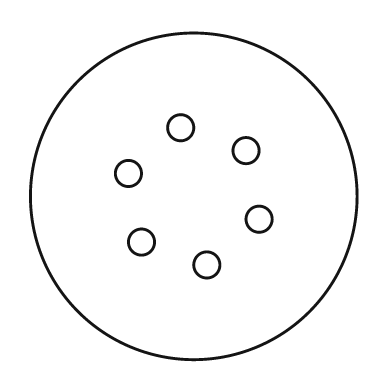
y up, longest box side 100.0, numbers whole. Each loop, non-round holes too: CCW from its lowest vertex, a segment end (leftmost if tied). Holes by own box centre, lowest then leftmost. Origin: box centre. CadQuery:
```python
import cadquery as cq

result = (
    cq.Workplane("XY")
    .moveTo(0.0, 0.0)
    .circle(50.0)
    .moveTo(4.0, -21.0)
    .circle(4.0)
    .moveTo(-16.0, -14.0)
    .circle(4.0)
    .moveTo(20.0, -7.0)
    .circle(4.0)
    .moveTo(-20.0, 7.0)
    .circle(4.0)
    .moveTo(16.0, 14.0)
    .circle(4.0)
    .moveTo(-4.0, 21.0)
    .circle(4.0)
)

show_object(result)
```